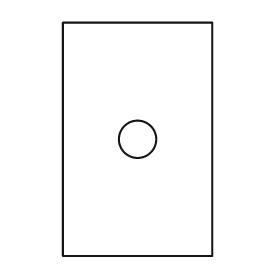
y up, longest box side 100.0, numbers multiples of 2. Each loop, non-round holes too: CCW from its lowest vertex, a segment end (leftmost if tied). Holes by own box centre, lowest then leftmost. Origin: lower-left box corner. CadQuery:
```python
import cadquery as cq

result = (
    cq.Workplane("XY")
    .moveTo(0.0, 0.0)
    .lineTo(64.0, 0.0)
    .lineTo(64.0, 100.0)
    .lineTo(0.0, 100.0)
    .close()
    .moveTo(32.0, 50.0)
    .circle(8.0)
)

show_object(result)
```